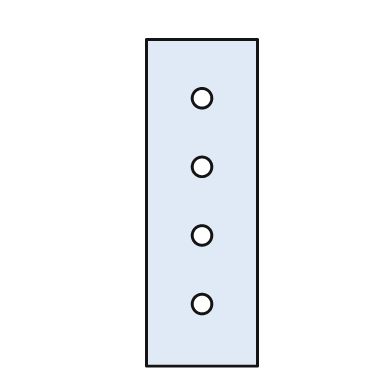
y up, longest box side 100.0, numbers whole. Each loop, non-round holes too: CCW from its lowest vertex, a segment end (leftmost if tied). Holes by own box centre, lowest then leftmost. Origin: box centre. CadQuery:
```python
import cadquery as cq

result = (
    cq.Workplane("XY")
    .moveTo(-17.0, -50.0)
    .lineTo(17.0, -50.0)
    .lineTo(17.0, 50.0)
    .lineTo(-17.0, 50.0)
    .close()
    .moveTo(0.0, -31.0)
    .circle(3.0)
    .moveTo(0.0, -10.0)
    .circle(3.0)
    .moveTo(0.0, 11.0)
    .circle(3.0)
    .moveTo(0.0, 32.0)
    .circle(3.0)
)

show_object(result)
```